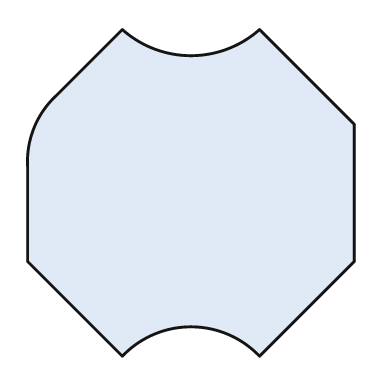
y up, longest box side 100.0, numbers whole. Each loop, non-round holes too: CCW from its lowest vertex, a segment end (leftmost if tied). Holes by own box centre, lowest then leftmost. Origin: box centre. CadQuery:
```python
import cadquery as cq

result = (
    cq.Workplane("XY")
    .moveTo(-21.0, -50.0)
    .threePointArc((0.0, -41.0), (21.0, -50.0))
    .lineTo(50.0, -21.0)
    .lineTo(50.0, 21.0)
    .lineTo(21.0, 50.0)
    .threePointArc((0.0, 42.0), (-21.0, 50.0))
    .lineTo(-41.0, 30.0)
    .threePointArc((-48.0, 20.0), (-50.0, 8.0))
    .lineTo(-50.0, -21.0)
    .close()
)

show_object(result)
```